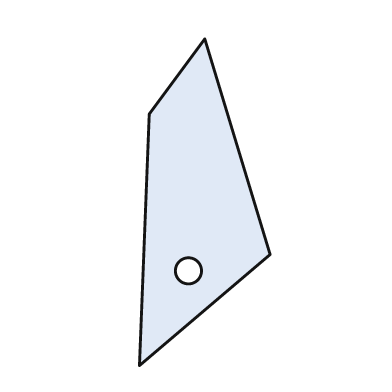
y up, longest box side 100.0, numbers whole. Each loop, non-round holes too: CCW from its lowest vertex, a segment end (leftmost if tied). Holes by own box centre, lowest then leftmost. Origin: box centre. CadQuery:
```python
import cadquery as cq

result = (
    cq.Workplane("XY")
    .moveTo(-20.0, -50.0)
    .lineTo(20.0, -16.0)
    .lineTo(0.0, 50.0)
    .lineTo(-17.0, 27.0)
    .close()
    .moveTo(-5.0, -21.0)
    .circle(4.0)
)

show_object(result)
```